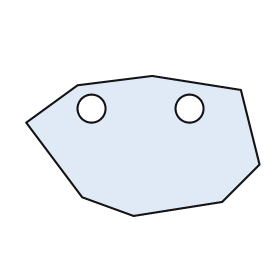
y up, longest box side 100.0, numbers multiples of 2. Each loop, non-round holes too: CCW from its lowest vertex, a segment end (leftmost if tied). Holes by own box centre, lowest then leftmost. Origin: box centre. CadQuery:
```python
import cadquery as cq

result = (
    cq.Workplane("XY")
    .moveTo(-4.0, -30.0)
    .lineTo(34.0, -24.0)
    .lineTo(50.0, -8.0)
    .lineTo(42.0, 24.0)
    .lineTo(4.0, 30.0)
    .lineTo(-28.0, 26.0)
    .lineTo(-50.0, 10.0)
    .lineTo(-26.0, -22.0)
    .close()
    .moveTo(-22.0, 16.0)
    .circle(6.0)
    .moveTo(20.0, 16.0)
    .circle(6.0)
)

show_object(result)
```